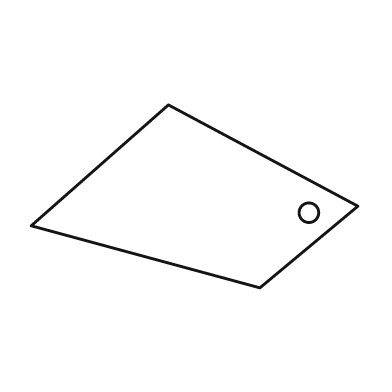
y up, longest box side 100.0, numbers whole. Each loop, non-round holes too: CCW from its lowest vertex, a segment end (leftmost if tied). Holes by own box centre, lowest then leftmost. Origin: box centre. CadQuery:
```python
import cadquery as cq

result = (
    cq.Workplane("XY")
    .moveTo(20.0, -28.0)
    .lineTo(50.0, -3.0)
    .lineTo(-8.0, 28.0)
    .lineTo(-50.0, -9.0)
    .close()
    .moveTo(35.0, -5.0)
    .circle(3.0)
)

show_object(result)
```